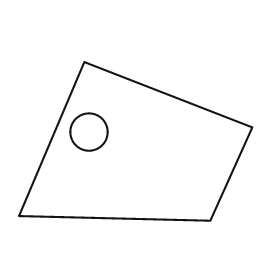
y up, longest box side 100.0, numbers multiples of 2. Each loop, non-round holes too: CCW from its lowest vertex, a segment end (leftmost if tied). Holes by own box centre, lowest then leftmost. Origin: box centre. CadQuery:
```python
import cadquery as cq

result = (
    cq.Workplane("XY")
    .moveTo(32.0, -34.0)
    .lineTo(50.0, 6.0)
    .lineTo(-22.0, 34.0)
    .lineTo(-50.0, -32.0)
    .close()
    .moveTo(-20.0, 4.0)
    .circle(8.0)
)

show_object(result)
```